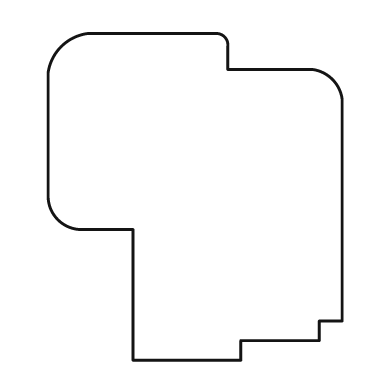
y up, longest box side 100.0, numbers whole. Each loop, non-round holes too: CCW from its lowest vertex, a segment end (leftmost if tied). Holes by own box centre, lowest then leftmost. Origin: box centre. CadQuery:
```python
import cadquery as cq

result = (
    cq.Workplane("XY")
    .moveTo(-19.0, -50.0)
    .lineTo(14.0, -50.0)
    .lineTo(14.0, -44.0)
    .lineTo(38.0, -44.0)
    .lineTo(38.0, -38.0)
    .lineTo(45.0, -38.0)
    .lineTo(45.0, 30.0)
    .threePointArc((42.0, 36.0), (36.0, 39.0))
    .lineTo(10.0, 39.0)
    .lineTo(10.0, 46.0)
    .threePointArc((9.0, 49.0), (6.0, 50.0))
    .lineTo(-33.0, 50.0)
    .threePointArc((-41.0, 46.0), (-45.0, 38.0))
    .lineTo(-45.0, 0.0)
    .threePointArc((-42.0, -7.0), (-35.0, -10.0))
    .lineTo(-19.0, -10.0)
    .close()
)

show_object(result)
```